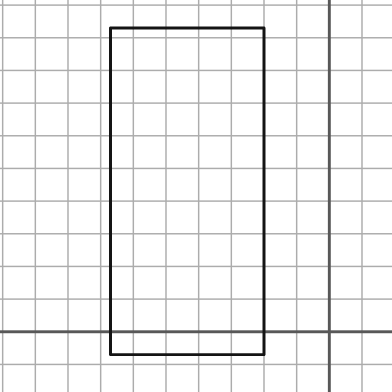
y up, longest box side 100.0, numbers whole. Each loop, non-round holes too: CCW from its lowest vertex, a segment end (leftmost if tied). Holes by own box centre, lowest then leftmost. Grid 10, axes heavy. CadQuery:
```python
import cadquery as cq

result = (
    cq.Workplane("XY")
    .moveTo(-67.0, -7.0)
    .lineTo(-20.0, -7.0)
    .lineTo(-20.0, 93.0)
    .lineTo(-67.0, 93.0)
    .close()
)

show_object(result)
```